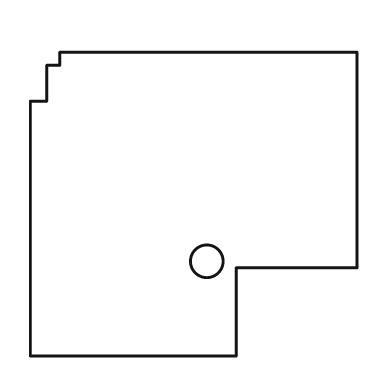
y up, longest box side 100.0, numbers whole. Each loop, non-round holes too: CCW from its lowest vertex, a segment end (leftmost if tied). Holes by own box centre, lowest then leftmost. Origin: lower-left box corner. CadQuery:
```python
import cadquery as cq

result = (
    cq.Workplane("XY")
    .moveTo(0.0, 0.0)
    .lineTo(63.0, 0.0)
    .lineTo(63.0, 27.0)
    .lineTo(100.0, 27.0)
    .lineTo(100.0, 93.0)
    .lineTo(9.0, 93.0)
    .lineTo(9.0, 89.0)
    .lineTo(5.0, 89.0)
    .lineTo(5.0, 78.0)
    .lineTo(0.0, 78.0)
    .close()
    .moveTo(54.0, 29.0)
    .circle(5.0)
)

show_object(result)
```